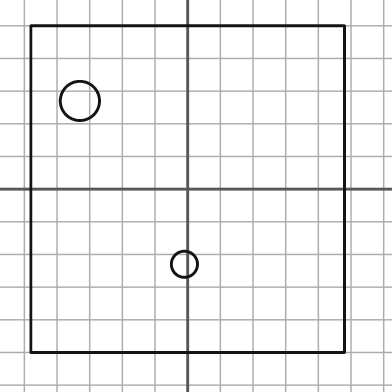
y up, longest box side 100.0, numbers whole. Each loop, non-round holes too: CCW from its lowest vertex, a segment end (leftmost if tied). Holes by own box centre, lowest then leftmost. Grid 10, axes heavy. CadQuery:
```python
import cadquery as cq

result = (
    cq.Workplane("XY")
    .moveTo(-48.0, -50.0)
    .lineTo(48.0, -50.0)
    .lineTo(48.0, 50.0)
    .lineTo(-48.0, 50.0)
    .close()
    .moveTo(-1.0, -23.0)
    .circle(4.0)
    .moveTo(-33.0, 27.0)
    .circle(6.0)
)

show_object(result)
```